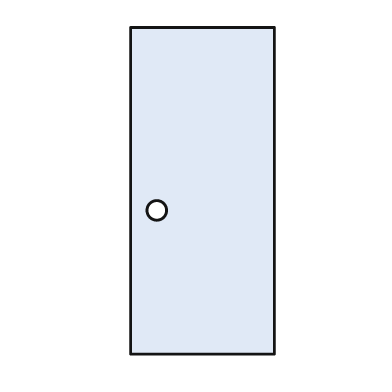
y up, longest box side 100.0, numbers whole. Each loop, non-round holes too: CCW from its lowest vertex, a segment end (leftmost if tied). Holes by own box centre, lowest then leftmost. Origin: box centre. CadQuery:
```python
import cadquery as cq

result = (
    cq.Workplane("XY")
    .moveTo(-22.0, -50.0)
    .lineTo(22.0, -50.0)
    .lineTo(22.0, 50.0)
    .lineTo(-22.0, 50.0)
    .close()
    .moveTo(-14.0, -6.0)
    .circle(3.0)
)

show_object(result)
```